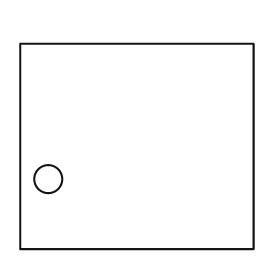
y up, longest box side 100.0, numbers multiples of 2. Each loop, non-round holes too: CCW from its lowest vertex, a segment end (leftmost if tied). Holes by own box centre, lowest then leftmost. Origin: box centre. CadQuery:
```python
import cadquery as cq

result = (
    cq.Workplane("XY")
    .moveTo(-50.0, -44.0)
    .lineTo(50.0, -44.0)
    .lineTo(50.0, 44.0)
    .lineTo(-50.0, 44.0)
    .close()
    .moveTo(-38.0, -14.0)
    .circle(6.0)
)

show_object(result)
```